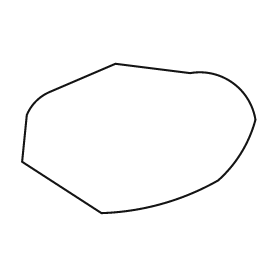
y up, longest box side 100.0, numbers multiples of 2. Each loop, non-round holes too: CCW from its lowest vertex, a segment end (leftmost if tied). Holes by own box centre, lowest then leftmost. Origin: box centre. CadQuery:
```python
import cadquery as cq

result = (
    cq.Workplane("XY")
    .moveTo(-16.0, -32.0)
    .threePointArc((10.0, -28.0), (34.0, -18.0))
    .threePointArc((44.0, -6.0), (50.0, 8.0))
    .threePointArc((40.0, 24.0), (22.0, 28.0))
    .lineTo(-10.0, 32.0)
    .lineTo(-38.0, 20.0)
    .threePointArc((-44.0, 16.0), (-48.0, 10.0))
    .lineTo(-50.0, -10.0)
    .close()
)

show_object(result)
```